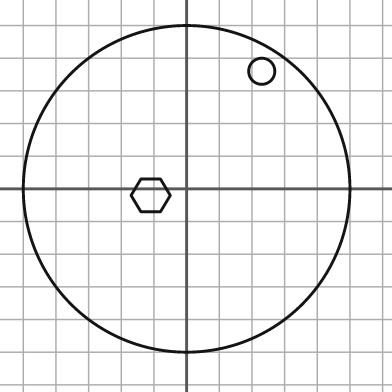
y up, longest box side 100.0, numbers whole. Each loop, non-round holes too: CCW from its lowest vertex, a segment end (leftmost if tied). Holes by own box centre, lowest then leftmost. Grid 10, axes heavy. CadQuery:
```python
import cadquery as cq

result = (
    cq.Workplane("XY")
    .moveTo(0.0, 0.0)
    .circle(50.0)
    .moveTo(-14.0, -7.0)
    .lineTo(-8.0, -7.0)
    .lineTo(-5.0, -2.0)
    .lineTo(-8.0, 3.0)
    .lineTo(-14.0, 3.0)
    .lineTo(-17.0, -2.0)
    .close()
    .moveTo(23.0, 36.0)
    .circle(4.0)
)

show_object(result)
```